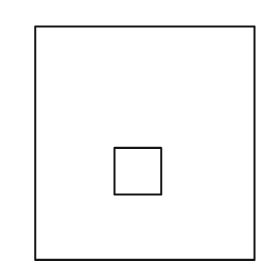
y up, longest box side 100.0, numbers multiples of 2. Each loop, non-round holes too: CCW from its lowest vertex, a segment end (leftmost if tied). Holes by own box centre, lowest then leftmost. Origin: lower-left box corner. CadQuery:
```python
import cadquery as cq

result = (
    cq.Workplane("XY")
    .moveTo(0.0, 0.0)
    .lineTo(94.0, 0.0)
    .lineTo(94.0, 100.0)
    .lineTo(0.0, 100.0)
    .close()
    .moveTo(34.0, 28.0)
    .lineTo(54.0, 28.0)
    .lineTo(54.0, 48.0)
    .lineTo(34.0, 48.0)
    .close()
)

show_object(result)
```